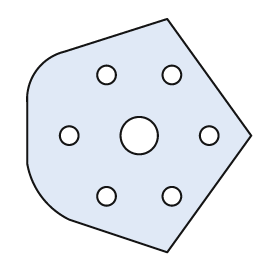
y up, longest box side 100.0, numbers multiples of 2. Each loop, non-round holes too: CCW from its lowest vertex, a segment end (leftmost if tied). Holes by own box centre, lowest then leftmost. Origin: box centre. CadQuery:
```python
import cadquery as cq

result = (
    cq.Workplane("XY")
    .moveTo(12.0, -50.0)
    .lineTo(48.0, 0.0)
    .lineTo(12.0, 50.0)
    .lineTo(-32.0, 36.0)
    .threePointArc((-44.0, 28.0), (-48.0, 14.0))
    .lineTo(-48.0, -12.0)
    .threePointArc((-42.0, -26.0), (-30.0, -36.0))
    .close()
    .moveTo(-14.0, -26.0)
    .circle(4.0)
    .moveTo(14.0, -26.0)
    .circle(4.0)
    .moveTo(-30.0, 0.0)
    .circle(4.0)
    .moveTo(0.0, 0.0)
    .circle(8.0)
    .moveTo(30.0, 0.0)
    .circle(4.0)
    .moveTo(-14.0, 26.0)
    .circle(4.0)
    .moveTo(14.0, 26.0)
    .circle(4.0)
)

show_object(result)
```